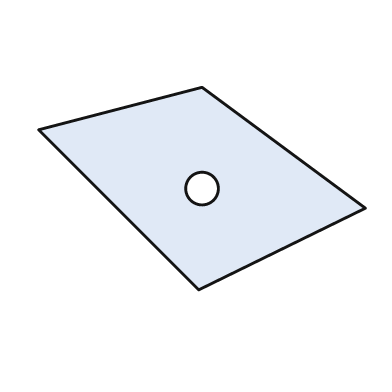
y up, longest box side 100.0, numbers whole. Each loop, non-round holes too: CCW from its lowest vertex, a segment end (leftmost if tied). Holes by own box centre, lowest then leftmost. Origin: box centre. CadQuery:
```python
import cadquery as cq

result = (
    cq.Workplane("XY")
    .moveTo(-1.0, -31.0)
    .lineTo(50.0, -6.0)
    .lineTo(0.0, 31.0)
    .lineTo(-50.0, 18.0)
    .close()
    .moveTo(0.0, 0.0)
    .circle(5.0)
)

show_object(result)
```